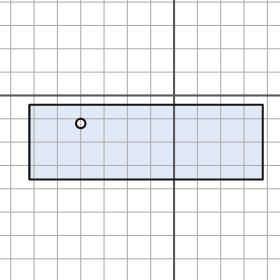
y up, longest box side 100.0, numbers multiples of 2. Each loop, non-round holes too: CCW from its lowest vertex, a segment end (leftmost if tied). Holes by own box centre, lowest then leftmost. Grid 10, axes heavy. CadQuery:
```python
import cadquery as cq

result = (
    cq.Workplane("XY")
    .moveTo(-62.0, -36.0)
    .lineTo(38.0, -36.0)
    .lineTo(38.0, -4.0)
    .lineTo(-62.0, -4.0)
    .close()
    .moveTo(-40.0, -12.0)
    .circle(2.0)
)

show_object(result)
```